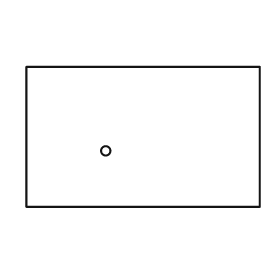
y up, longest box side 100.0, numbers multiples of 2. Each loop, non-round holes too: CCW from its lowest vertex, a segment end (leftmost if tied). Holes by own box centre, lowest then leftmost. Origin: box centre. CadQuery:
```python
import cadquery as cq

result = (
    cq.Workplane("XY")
    .moveTo(-50.0, -30.0)
    .lineTo(50.0, -30.0)
    .lineTo(50.0, 30.0)
    .lineTo(-50.0, 30.0)
    .close()
    .moveTo(-16.0, -6.0)
    .circle(2.0)
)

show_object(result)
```